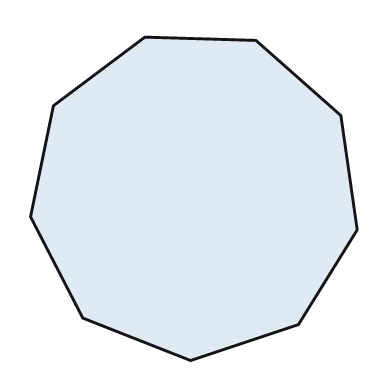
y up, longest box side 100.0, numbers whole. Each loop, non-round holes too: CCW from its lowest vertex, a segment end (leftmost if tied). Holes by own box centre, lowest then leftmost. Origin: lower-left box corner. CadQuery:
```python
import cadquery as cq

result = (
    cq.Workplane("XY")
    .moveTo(49.0, 0.0)
    .lineTo(82.0, 11.0)
    .lineTo(100.0, 40.0)
    .lineTo(95.0, 75.0)
    .lineTo(69.0, 98.0)
    .lineTo(35.0, 99.0)
    .lineTo(7.0, 78.0)
    .lineTo(0.0, 44.0)
    .lineTo(16.0, 13.0)
    .close()
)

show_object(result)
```